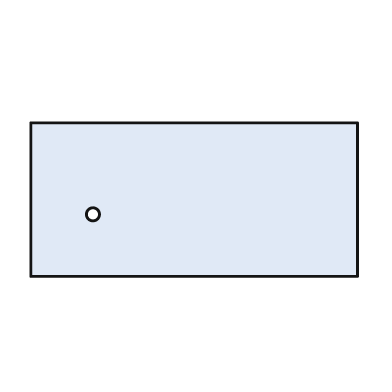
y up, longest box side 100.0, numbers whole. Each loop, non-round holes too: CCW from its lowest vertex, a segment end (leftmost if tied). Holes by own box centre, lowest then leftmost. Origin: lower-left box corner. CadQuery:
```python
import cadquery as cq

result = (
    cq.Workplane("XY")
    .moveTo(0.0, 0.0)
    .lineTo(100.0, 0.0)
    .lineTo(100.0, 47.0)
    .lineTo(0.0, 47.0)
    .close()
    .moveTo(19.0, 19.0)
    .circle(2.0)
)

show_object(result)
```